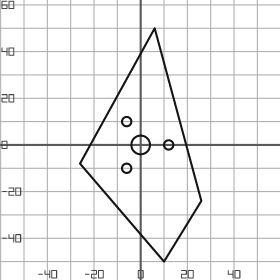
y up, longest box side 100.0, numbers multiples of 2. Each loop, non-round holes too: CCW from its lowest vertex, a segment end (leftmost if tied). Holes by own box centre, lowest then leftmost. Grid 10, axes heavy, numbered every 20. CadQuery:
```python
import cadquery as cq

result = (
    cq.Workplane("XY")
    .moveTo(10.0, -50.0)
    .lineTo(26.0, -24.0)
    .lineTo(6.0, 50.0)
    .lineTo(-26.0, -8.0)
    .close()
    .moveTo(-6.0, -10.0)
    .circle(2.0)
    .moveTo(0.0, 0.0)
    .circle(4.0)
    .moveTo(12.0, 0.0)
    .circle(2.0)
    .moveTo(-6.0, 10.0)
    .circle(2.0)
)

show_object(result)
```